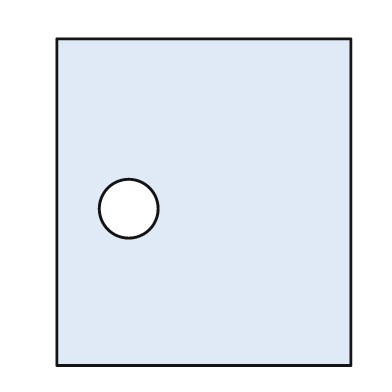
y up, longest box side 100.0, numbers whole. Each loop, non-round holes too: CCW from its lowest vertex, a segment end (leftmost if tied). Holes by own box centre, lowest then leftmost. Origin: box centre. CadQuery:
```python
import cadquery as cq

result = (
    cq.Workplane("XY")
    .moveTo(-45.0, -50.0)
    .lineTo(45.0, -50.0)
    .lineTo(45.0, 50.0)
    .lineTo(-45.0, 50.0)
    .close()
    .moveTo(-23.0, -2.0)
    .circle(9.0)
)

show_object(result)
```